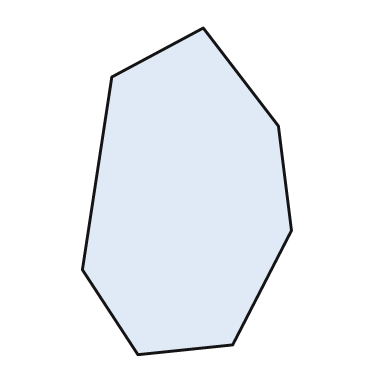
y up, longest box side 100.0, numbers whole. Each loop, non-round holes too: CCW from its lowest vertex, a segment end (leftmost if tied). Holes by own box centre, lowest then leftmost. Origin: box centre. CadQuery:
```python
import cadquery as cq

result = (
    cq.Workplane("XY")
    .moveTo(-15.0, -50.0)
    .lineTo(14.0, -47.0)
    .lineTo(32.0, -12.0)
    .lineTo(28.0, 20.0)
    .lineTo(5.0, 50.0)
    .lineTo(-23.0, 35.0)
    .lineTo(-32.0, -24.0)
    .close()
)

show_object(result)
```